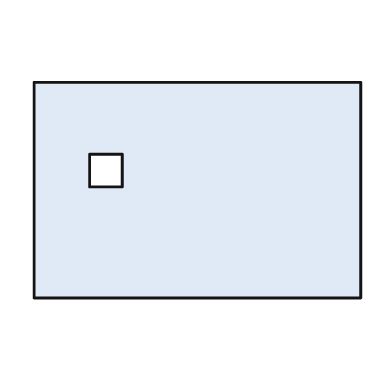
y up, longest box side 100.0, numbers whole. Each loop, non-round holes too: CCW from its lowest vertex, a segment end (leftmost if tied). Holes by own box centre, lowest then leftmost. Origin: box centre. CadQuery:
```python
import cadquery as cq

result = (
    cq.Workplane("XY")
    .moveTo(-50.0, -33.0)
    .lineTo(50.0, -33.0)
    .lineTo(50.0, 33.0)
    .lineTo(-50.0, 33.0)
    .close()
    .moveTo(-33.0, 1.0)
    .lineTo(-23.0, 1.0)
    .lineTo(-23.0, 11.0)
    .lineTo(-33.0, 11.0)
    .close()
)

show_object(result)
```